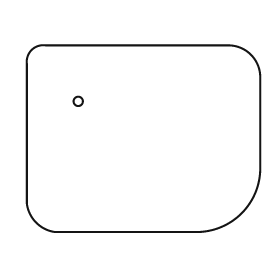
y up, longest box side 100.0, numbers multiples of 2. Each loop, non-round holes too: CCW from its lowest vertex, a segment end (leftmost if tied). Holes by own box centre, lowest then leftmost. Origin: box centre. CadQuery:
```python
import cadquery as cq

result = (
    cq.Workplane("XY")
    .moveTo(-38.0, -40.0)
    .lineTo(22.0, -40.0)
    .threePointArc((42.0, -32.0), (50.0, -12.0))
    .lineTo(50.0, 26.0)
    .threePointArc((46.0, 36.0), (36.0, 40.0))
    .lineTo(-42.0, 40.0)
    .threePointArc((-48.0, 38.0), (-50.0, 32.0))
    .lineTo(-50.0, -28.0)
    .threePointArc((-46.0, -36.0), (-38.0, -40.0))
    .close()
    .moveTo(-28.0, 16.0)
    .circle(2.0)
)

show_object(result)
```